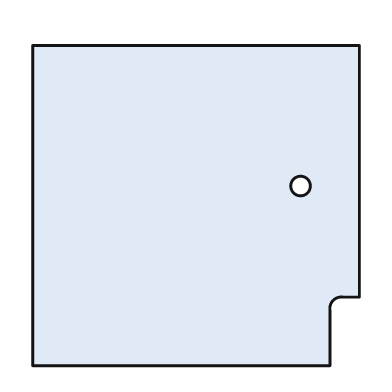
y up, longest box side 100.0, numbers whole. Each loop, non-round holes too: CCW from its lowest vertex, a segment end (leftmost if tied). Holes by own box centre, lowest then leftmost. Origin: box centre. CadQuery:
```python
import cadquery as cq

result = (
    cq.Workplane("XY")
    .moveTo(-50.0, -49.0)
    .lineTo(41.0, -49.0)
    .lineTo(41.0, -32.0)
    .threePointArc((42.0, -29.0), (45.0, -28.0))
    .lineTo(50.0, -28.0)
    .lineTo(50.0, 49.0)
    .lineTo(-50.0, 49.0)
    .close()
    .moveTo(32.0, 6.0)
    .circle(3.0)
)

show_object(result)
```